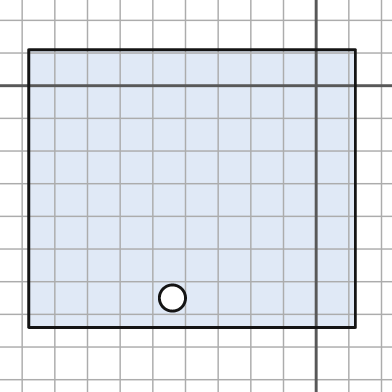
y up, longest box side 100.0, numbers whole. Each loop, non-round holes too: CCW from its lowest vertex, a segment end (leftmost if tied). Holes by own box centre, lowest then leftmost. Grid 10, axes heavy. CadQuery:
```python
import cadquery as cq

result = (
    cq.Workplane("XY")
    .moveTo(-88.0, -74.0)
    .lineTo(12.0, -74.0)
    .lineTo(12.0, 11.0)
    .lineTo(-88.0, 11.0)
    .close()
    .moveTo(-44.0, -65.0)
    .circle(4.0)
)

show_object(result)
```